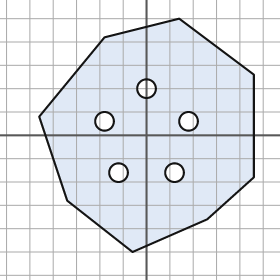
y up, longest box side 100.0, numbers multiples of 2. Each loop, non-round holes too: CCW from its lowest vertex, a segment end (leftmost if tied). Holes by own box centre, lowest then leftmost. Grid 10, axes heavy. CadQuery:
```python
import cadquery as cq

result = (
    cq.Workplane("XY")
    .moveTo(-6.0, -50.0)
    .lineTo(26.0, -36.0)
    .lineTo(46.0, -18.0)
    .lineTo(46.0, 26.0)
    .lineTo(14.0, 50.0)
    .lineTo(-18.0, 42.0)
    .lineTo(-46.0, 8.0)
    .lineTo(-34.0, -28.0)
    .close()
    .moveTo(-12.0, -16.0)
    .circle(4.0)
    .moveTo(12.0, -16.0)
    .circle(4.0)
    .moveTo(-18.0, 6.0)
    .circle(4.0)
    .moveTo(18.0, 6.0)
    .circle(4.0)
    .moveTo(0.0, 20.0)
    .circle(4.0)
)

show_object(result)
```